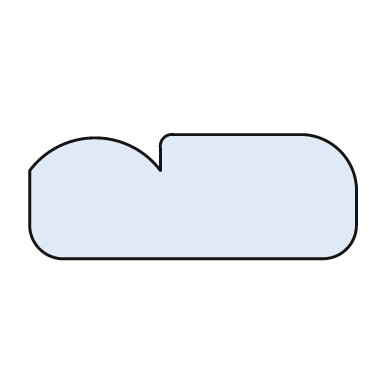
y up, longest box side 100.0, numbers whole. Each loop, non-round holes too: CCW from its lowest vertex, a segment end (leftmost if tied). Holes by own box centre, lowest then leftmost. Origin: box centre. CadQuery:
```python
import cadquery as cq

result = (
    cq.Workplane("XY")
    .moveTo(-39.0, -19.0)
    .lineTo(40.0, -19.0)
    .threePointArc((47.0, -16.0), (50.0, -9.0))
    .lineTo(50.0, 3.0)
    .threePointArc((45.0, 14.0), (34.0, 19.0))
    .lineTo(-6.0, 19.0)
    .threePointArc((-9.0, 18.0), (-10.0, 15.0))
    .lineTo(-10.0, 8.0)
    .threePointArc((-30.0, 18.0), (-50.0, 8.0))
    .lineTo(-50.0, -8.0)
    .threePointArc((-47.0, -16.0), (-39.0, -19.0))
    .close()
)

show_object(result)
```